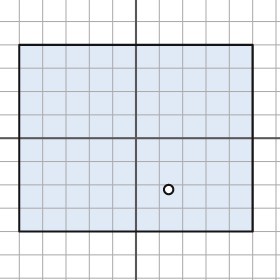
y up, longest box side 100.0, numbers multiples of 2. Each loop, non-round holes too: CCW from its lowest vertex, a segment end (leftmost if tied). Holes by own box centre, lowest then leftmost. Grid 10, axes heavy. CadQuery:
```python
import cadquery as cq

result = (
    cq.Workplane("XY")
    .moveTo(-50.0, -40.0)
    .lineTo(50.0, -40.0)
    .lineTo(50.0, 40.0)
    .lineTo(-50.0, 40.0)
    .close()
    .moveTo(14.0, -22.0)
    .circle(2.0)
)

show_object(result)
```